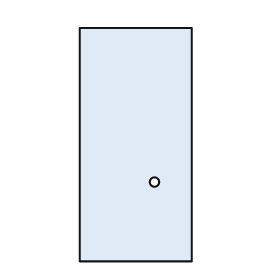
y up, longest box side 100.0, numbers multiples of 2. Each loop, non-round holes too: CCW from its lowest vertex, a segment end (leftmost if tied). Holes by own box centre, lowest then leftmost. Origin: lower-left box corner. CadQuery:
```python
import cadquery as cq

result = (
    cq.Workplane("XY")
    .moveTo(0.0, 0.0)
    .lineTo(48.0, 0.0)
    .lineTo(48.0, 100.0)
    .lineTo(0.0, 100.0)
    .close()
    .moveTo(32.0, 34.0)
    .circle(2.0)
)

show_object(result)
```